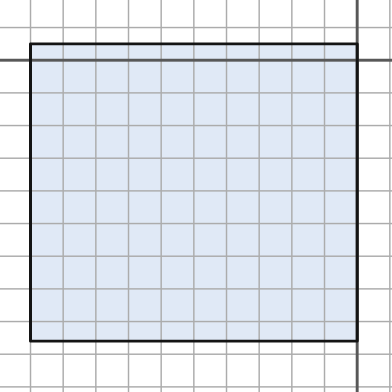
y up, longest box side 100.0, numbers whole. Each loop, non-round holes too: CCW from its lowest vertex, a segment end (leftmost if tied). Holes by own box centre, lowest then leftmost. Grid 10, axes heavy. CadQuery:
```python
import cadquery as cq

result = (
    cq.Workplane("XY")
    .moveTo(-100.0, -86.0)
    .lineTo(0.0, -86.0)
    .lineTo(0.0, 5.0)
    .lineTo(-100.0, 5.0)
    .close()
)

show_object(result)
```